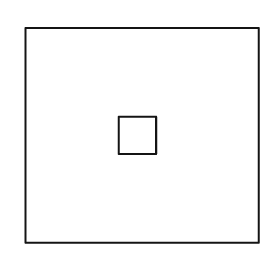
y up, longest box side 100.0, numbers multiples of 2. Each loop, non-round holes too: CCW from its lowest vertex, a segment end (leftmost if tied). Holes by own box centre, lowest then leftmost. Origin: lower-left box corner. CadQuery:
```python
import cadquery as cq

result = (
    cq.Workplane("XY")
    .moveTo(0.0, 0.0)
    .lineTo(100.0, 0.0)
    .lineTo(100.0, 92.0)
    .lineTo(0.0, 92.0)
    .close()
    .moveTo(40.0, 38.0)
    .lineTo(56.0, 38.0)
    .lineTo(56.0, 54.0)
    .lineTo(40.0, 54.0)
    .close()
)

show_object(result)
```